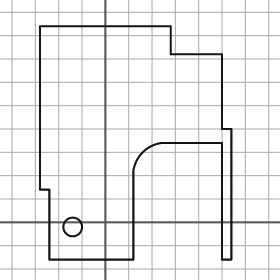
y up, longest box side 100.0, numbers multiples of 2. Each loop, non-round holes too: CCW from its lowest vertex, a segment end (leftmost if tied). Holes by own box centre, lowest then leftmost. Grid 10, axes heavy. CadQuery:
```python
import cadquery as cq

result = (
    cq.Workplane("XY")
    .moveTo(-24.0, -16.0)
    .lineTo(12.0, -16.0)
    .lineTo(12.0, 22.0)
    .threePointArc((16.0, 30.0), (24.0, 34.0))
    .lineTo(50.0, 34.0)
    .lineTo(50.0, -16.0)
    .lineTo(54.0, -16.0)
    .lineTo(54.0, 40.0)
    .lineTo(50.0, 40.0)
    .lineTo(50.0, 72.0)
    .lineTo(28.0, 72.0)
    .lineTo(28.0, 84.0)
    .lineTo(-28.0, 84.0)
    .lineTo(-28.0, 14.0)
    .lineTo(-24.0, 14.0)
    .close()
    .moveTo(-14.0, -2.0)
    .circle(4.0)
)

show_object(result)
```